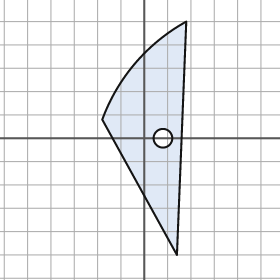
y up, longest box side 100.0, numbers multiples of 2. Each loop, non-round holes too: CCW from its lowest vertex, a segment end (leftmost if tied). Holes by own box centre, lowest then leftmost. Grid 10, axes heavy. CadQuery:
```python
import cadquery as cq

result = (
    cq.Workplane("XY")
    .moveTo(14.0, -50.0)
    .lineTo(18.0, 50.0)
    .threePointArc((-4.0, 32.0), (-18.0, 8.0))
    .close()
    .moveTo(8.0, 0.0)
    .circle(4.0)
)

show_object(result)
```